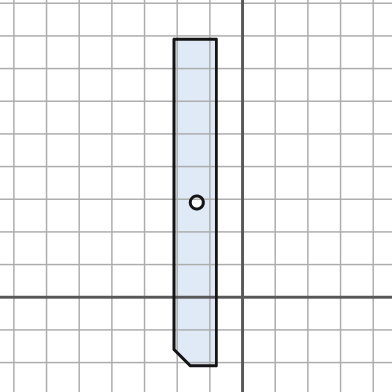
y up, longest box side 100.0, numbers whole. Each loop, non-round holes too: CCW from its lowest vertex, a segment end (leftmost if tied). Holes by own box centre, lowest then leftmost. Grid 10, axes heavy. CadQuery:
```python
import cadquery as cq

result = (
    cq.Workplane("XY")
    .moveTo(-16.0, -21.0)
    .lineTo(-8.0, -21.0)
    .lineTo(-8.0, 79.0)
    .lineTo(-21.0, 79.0)
    .lineTo(-21.0, -16.0)
    .close()
    .moveTo(-14.0, 29.0)
    .circle(2.0)
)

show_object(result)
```